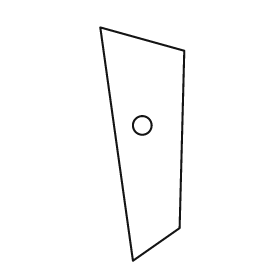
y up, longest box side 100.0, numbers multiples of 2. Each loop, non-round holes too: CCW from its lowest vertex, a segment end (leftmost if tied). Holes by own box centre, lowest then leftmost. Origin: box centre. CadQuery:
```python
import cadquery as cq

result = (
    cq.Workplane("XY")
    .moveTo(-4.0, -50.0)
    .lineTo(16.0, -36.0)
    .lineTo(18.0, 40.0)
    .lineTo(-18.0, 50.0)
    .close()
    .moveTo(0.0, 8.0)
    .circle(4.0)
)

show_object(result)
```